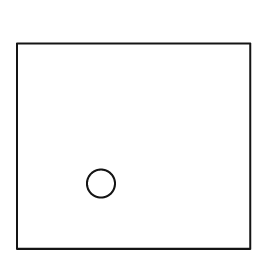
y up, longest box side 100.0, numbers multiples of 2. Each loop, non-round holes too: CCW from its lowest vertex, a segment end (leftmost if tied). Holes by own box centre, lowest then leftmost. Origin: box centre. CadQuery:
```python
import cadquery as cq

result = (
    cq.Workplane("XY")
    .moveTo(-50.0, -44.0)
    .lineTo(50.0, -44.0)
    .lineTo(50.0, 44.0)
    .lineTo(-50.0, 44.0)
    .close()
    .moveTo(-14.0, -16.0)
    .circle(6.0)
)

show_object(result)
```